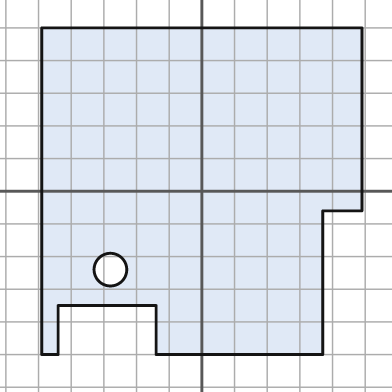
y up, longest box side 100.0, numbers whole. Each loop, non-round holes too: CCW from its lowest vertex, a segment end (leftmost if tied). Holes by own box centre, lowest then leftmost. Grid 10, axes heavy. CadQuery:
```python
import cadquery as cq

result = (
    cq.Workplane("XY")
    .moveTo(-49.0, -50.0)
    .lineTo(-44.0, -50.0)
    .lineTo(-44.0, -35.0)
    .lineTo(-14.0, -35.0)
    .lineTo(-14.0, -50.0)
    .lineTo(37.0, -50.0)
    .lineTo(37.0, -6.0)
    .lineTo(49.0, -6.0)
    .lineTo(49.0, 50.0)
    .lineTo(-49.0, 50.0)
    .close()
    .moveTo(-28.0, -24.0)
    .circle(5.0)
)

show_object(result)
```